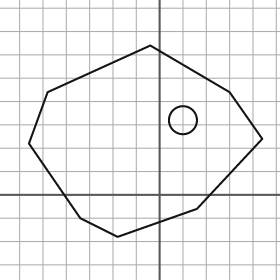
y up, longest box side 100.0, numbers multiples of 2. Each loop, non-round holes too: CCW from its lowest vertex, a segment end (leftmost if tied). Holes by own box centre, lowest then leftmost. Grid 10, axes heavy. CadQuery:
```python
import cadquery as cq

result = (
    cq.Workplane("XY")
    .moveTo(-18.0, -18.0)
    .lineTo(16.0, -6.0)
    .lineTo(44.0, 24.0)
    .lineTo(30.0, 44.0)
    .lineTo(-4.0, 64.0)
    .lineTo(-48.0, 44.0)
    .lineTo(-56.0, 22.0)
    .lineTo(-34.0, -10.0)
    .close()
    .moveTo(10.0, 32.0)
    .circle(6.0)
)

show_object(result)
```